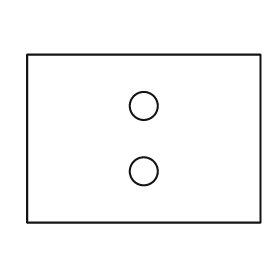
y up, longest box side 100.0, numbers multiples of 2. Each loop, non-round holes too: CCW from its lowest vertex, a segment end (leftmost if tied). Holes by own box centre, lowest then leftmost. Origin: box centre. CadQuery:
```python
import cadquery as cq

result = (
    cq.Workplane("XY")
    .moveTo(-50.0, -36.0)
    .lineTo(50.0, -36.0)
    .lineTo(50.0, 36.0)
    .lineTo(-50.0, 36.0)
    .close()
    .moveTo(0.0, -14.0)
    .circle(6.0)
    .moveTo(0.0, 14.0)
    .circle(6.0)
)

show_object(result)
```